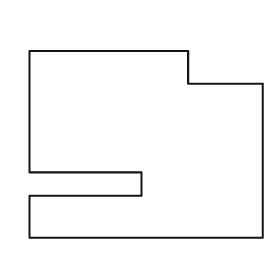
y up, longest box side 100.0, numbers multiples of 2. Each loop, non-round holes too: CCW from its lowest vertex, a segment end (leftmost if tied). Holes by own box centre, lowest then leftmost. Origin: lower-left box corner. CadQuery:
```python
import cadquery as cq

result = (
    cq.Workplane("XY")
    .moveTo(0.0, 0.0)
    .lineTo(100.0, 0.0)
    .lineTo(100.0, 66.0)
    .lineTo(68.0, 66.0)
    .lineTo(68.0, 80.0)
    .lineTo(0.0, 80.0)
    .lineTo(0.0, 28.0)
    .lineTo(48.0, 28.0)
    .lineTo(48.0, 18.0)
    .lineTo(0.0, 18.0)
    .close()
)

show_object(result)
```